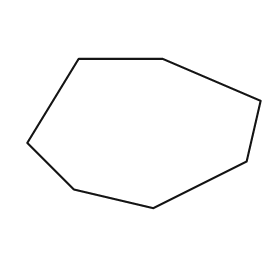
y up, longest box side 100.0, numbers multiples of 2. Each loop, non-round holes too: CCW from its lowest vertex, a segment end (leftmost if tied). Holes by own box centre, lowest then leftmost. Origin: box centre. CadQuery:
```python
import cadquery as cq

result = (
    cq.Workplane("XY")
    .moveTo(4.0, -32.0)
    .lineTo(44.0, -12.0)
    .lineTo(50.0, 14.0)
    .lineTo(8.0, 32.0)
    .lineTo(-28.0, 32.0)
    .lineTo(-50.0, -4.0)
    .lineTo(-30.0, -24.0)
    .close()
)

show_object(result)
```